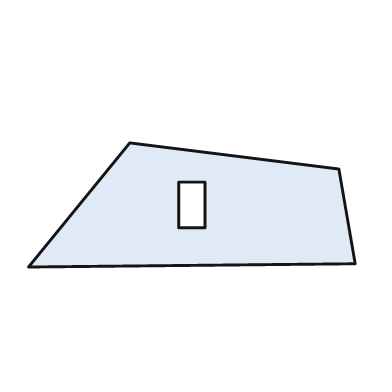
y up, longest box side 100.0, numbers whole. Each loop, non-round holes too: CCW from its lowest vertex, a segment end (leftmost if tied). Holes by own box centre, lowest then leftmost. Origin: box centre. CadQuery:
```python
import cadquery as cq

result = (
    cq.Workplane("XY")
    .moveTo(-50.0, -19.0)
    .lineTo(50.0, -18.0)
    .lineTo(45.0, 11.0)
    .lineTo(-19.0, 19.0)
    .close()
    .moveTo(-4.0, -7.0)
    .lineTo(4.0, -7.0)
    .lineTo(4.0, 7.0)
    .lineTo(-4.0, 7.0)
    .close()
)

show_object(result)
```